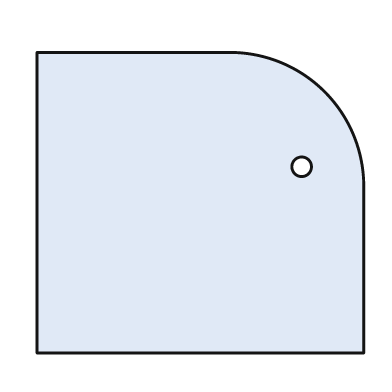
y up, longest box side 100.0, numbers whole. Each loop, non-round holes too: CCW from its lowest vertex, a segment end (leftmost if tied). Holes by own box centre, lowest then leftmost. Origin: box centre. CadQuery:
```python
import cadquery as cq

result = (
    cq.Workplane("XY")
    .moveTo(-50.0, -46.0)
    .lineTo(50.0, -46.0)
    .lineTo(50.0, 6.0)
    .threePointArc((38.0, 34.0), (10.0, 46.0))
    .lineTo(-50.0, 46.0)
    .close()
    .moveTo(31.0, 11.0)
    .circle(3.0)
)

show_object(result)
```